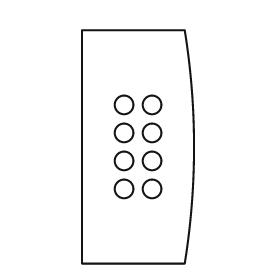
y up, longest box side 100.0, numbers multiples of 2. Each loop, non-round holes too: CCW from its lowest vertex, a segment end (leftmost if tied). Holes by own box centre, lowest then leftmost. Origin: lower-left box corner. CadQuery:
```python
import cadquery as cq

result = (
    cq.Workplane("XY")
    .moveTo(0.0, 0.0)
    .lineTo(44.0, 0.0)
    .threePointArc((48.0, 50.0), (44.0, 100.0))
    .lineTo(0.0, 100.0)
    .close()
    .moveTo(18.0, 32.0)
    .circle(4.0)
    .moveTo(30.0, 32.0)
    .circle(4.0)
    .moveTo(18.0, 44.0)
    .circle(4.0)
    .moveTo(30.0, 44.0)
    .circle(4.0)
    .moveTo(18.0, 56.0)
    .circle(4.0)
    .moveTo(30.0, 56.0)
    .circle(4.0)
    .moveTo(18.0, 68.0)
    .circle(4.0)
    .moveTo(30.0, 68.0)
    .circle(4.0)
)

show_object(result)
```